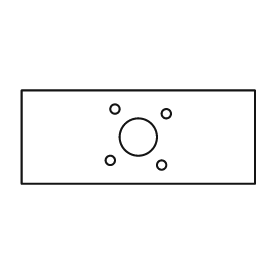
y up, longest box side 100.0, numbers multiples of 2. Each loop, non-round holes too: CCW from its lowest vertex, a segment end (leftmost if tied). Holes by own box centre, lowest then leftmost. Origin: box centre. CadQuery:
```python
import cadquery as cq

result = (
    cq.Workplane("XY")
    .moveTo(-50.0, -20.0)
    .lineTo(50.0, -20.0)
    .lineTo(50.0, 20.0)
    .lineTo(-50.0, 20.0)
    .close()
    .moveTo(10.0, -12.0)
    .circle(2.0)
    .moveTo(-12.0, -10.0)
    .circle(2.0)
    .moveTo(0.0, 0.0)
    .circle(8.0)
    .moveTo(12.0, 10.0)
    .circle(2.0)
    .moveTo(-10.0, 12.0)
    .circle(2.0)
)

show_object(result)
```